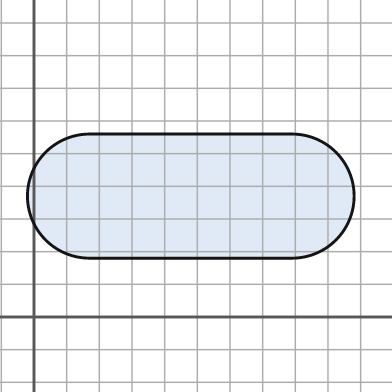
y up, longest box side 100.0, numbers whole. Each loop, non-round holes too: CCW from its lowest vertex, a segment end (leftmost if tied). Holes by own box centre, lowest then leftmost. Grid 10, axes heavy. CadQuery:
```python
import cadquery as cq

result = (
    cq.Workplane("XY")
    .moveTo(17.0, 18.0)
    .lineTo(79.0, 18.0)
    .threePointArc((98.0, 37.0), (79.0, 56.0))
    .lineTo(17.0, 56.0)
    .threePointArc((-2.0, 37.0), (17.0, 18.0))
    .close()
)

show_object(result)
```